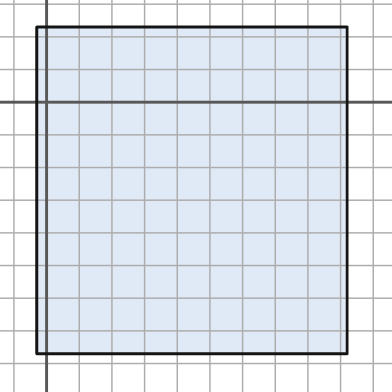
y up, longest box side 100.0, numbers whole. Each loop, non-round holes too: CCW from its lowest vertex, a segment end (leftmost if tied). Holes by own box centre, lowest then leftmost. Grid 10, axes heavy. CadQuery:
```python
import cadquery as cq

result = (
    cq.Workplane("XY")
    .moveTo(-3.0, -77.0)
    .lineTo(92.0, -77.0)
    .lineTo(92.0, 23.0)
    .lineTo(-3.0, 23.0)
    .close()
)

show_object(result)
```